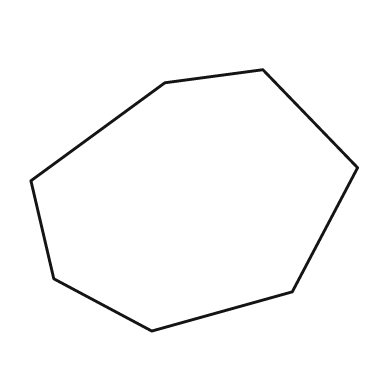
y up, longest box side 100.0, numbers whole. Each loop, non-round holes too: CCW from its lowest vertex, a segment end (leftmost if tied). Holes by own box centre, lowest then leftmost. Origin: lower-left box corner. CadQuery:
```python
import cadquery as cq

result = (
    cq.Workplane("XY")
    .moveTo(37.0, 0.0)
    .lineTo(80.0, 12.0)
    .lineTo(100.0, 50.0)
    .lineTo(71.0, 80.0)
    .lineTo(41.0, 76.0)
    .lineTo(0.0, 46.0)
    .lineTo(7.0, 16.0)
    .close()
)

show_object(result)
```